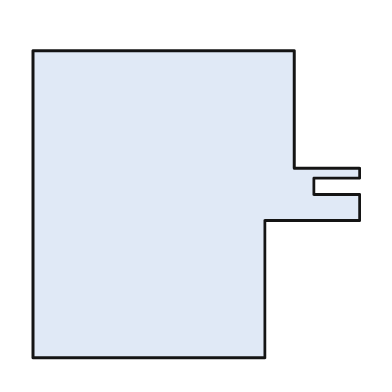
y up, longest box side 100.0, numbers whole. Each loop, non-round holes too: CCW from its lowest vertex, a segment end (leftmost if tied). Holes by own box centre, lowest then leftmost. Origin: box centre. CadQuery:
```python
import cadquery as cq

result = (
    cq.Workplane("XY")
    .moveTo(-50.0, -47.0)
    .lineTo(21.0, -47.0)
    .lineTo(21.0, -5.0)
    .lineTo(50.0, -5.0)
    .lineTo(50.0, 3.0)
    .lineTo(36.0, 3.0)
    .lineTo(36.0, 8.0)
    .lineTo(50.0, 8.0)
    .lineTo(50.0, 11.0)
    .lineTo(30.0, 11.0)
    .lineTo(30.0, 47.0)
    .lineTo(-50.0, 47.0)
    .close()
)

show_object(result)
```